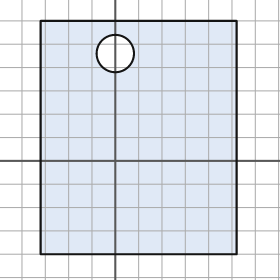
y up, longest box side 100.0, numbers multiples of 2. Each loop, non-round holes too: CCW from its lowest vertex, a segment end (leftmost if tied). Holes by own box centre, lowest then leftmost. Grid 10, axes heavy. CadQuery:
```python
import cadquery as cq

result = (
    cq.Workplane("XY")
    .moveTo(-32.0, -40.0)
    .lineTo(52.0, -40.0)
    .lineTo(52.0, 60.0)
    .lineTo(-32.0, 60.0)
    .close()
    .moveTo(0.0, 46.0)
    .circle(8.0)
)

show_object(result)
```